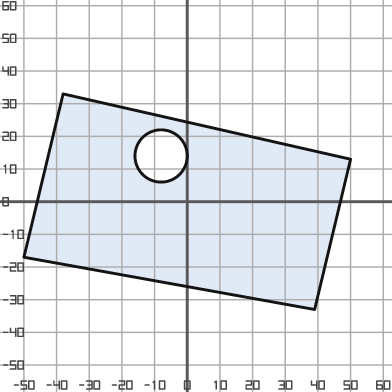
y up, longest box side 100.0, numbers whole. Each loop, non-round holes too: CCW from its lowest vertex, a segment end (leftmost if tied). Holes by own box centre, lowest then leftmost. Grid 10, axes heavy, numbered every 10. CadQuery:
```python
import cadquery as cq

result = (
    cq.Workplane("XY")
    .moveTo(39.0, -33.0)
    .lineTo(50.0, 13.0)
    .lineTo(-38.0, 33.0)
    .lineTo(-50.0, -17.0)
    .close()
    .moveTo(-8.0, 14.0)
    .circle(8.0)
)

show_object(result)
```